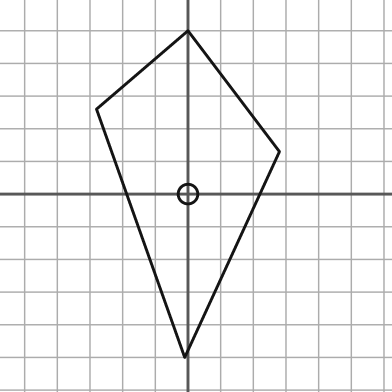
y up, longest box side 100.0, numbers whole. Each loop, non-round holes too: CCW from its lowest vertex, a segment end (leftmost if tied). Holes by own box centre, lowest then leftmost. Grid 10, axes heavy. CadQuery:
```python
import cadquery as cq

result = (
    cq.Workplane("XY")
    .moveTo(-1.0, -50.0)
    .lineTo(28.0, 13.0)
    .lineTo(0.0, 50.0)
    .lineTo(-28.0, 26.0)
    .close()
    .moveTo(0.0, 0.0)
    .circle(3.0)
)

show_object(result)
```